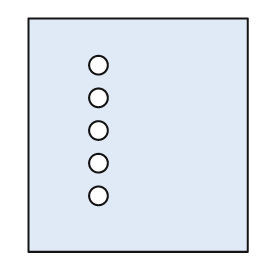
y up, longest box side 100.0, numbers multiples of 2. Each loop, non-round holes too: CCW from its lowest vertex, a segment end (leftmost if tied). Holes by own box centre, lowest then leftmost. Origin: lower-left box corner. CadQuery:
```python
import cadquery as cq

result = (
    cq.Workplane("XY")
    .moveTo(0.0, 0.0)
    .lineTo(94.0, 0.0)
    .lineTo(94.0, 100.0)
    .lineTo(0.0, 100.0)
    .close()
    .moveTo(30.0, 24.0)
    .circle(4.0)
    .moveTo(30.0, 38.0)
    .circle(4.0)
    .moveTo(30.0, 52.0)
    .circle(4.0)
    .moveTo(30.0, 66.0)
    .circle(4.0)
    .moveTo(30.0, 80.0)
    .circle(4.0)
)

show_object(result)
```